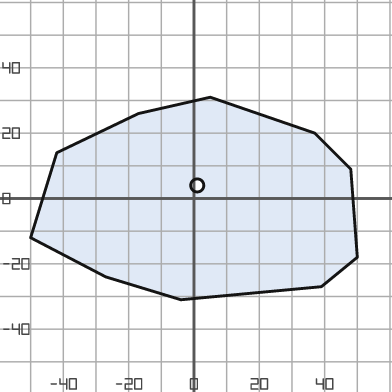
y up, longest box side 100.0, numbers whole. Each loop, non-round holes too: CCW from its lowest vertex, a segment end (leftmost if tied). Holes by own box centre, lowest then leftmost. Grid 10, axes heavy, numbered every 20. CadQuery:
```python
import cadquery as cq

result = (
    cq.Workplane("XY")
    .moveTo(-4.0, -31.0)
    .lineTo(39.0, -27.0)
    .lineTo(50.0, -18.0)
    .lineTo(48.0, 9.0)
    .lineTo(37.0, 20.0)
    .lineTo(5.0, 31.0)
    .lineTo(-17.0, 26.0)
    .lineTo(-42.0, 14.0)
    .lineTo(-50.0, -12.0)
    .lineTo(-27.0, -24.0)
    .close()
    .moveTo(1.0, 4.0)
    .circle(2.0)
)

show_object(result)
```